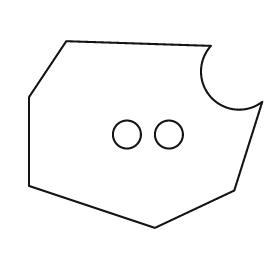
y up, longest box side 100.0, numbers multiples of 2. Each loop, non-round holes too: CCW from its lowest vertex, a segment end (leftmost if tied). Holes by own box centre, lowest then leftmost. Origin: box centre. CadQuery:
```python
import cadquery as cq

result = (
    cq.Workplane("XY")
    .moveTo(4.0, -40.0)
    .lineTo(38.0, -24.0)
    .lineTo(50.0, 14.0)
    .threePointArc((28.0, 16.0), (28.0, 38.0))
    .lineTo(-34.0, 40.0)
    .lineTo(-50.0, 16.0)
    .lineTo(-50.0, -22.0)
    .close()
    .moveTo(-8.0, 0.0)
    .circle(6.0)
    .moveTo(10.0, 0.0)
    .circle(6.0)
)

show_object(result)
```